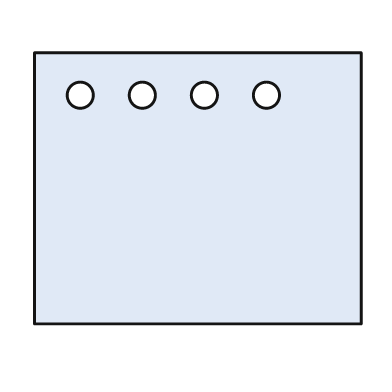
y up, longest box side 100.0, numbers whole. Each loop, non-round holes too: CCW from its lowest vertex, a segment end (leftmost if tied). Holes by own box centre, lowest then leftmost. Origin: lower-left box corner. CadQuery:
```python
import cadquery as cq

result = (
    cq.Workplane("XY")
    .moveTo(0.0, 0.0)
    .lineTo(100.0, 0.0)
    .lineTo(100.0, 83.0)
    .lineTo(0.0, 83.0)
    .close()
    .moveTo(14.0, 70.0)
    .circle(4.0)
    .moveTo(33.0, 70.0)
    .circle(4.0)
    .moveTo(52.0, 70.0)
    .circle(4.0)
    .moveTo(71.0, 70.0)
    .circle(4.0)
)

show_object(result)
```